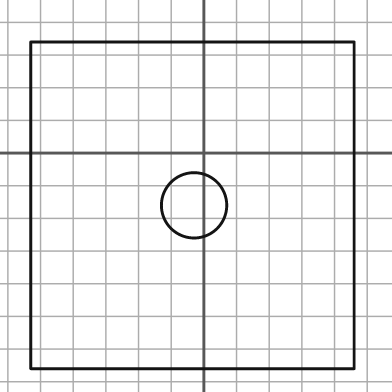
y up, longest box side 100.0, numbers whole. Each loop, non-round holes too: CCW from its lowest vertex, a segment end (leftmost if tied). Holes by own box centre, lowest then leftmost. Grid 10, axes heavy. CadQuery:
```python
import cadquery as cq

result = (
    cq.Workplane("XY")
    .moveTo(-53.0, -66.0)
    .lineTo(46.0, -66.0)
    .lineTo(46.0, 34.0)
    .lineTo(-53.0, 34.0)
    .close()
    .moveTo(-3.0, -16.0)
    .circle(10.0)
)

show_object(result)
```